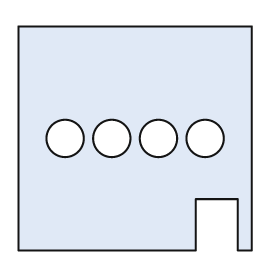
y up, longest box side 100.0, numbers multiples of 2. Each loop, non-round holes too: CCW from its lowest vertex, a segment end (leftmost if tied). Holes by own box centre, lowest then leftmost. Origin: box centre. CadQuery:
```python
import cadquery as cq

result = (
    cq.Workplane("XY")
    .moveTo(-50.0, -48.0)
    .lineTo(26.0, -48.0)
    .lineTo(26.0, -26.0)
    .lineTo(44.0, -26.0)
    .lineTo(44.0, -48.0)
    .lineTo(50.0, -48.0)
    .lineTo(50.0, 48.0)
    .lineTo(-50.0, 48.0)
    .close()
    .moveTo(-30.0, 0.0)
    .circle(8.0)
    .moveTo(-10.0, 0.0)
    .circle(8.0)
    .moveTo(10.0, 0.0)
    .circle(8.0)
    .moveTo(30.0, 0.0)
    .circle(8.0)
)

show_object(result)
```